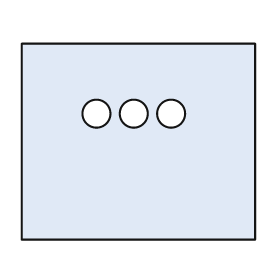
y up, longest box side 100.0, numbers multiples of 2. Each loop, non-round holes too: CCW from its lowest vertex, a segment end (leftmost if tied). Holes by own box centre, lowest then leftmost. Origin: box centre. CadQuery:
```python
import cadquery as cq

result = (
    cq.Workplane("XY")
    .moveTo(-50.0, -42.0)
    .lineTo(50.0, -42.0)
    .lineTo(50.0, 42.0)
    .lineTo(-50.0, 42.0)
    .close()
    .moveTo(-18.0, 12.0)
    .circle(6.0)
    .moveTo(-2.0, 12.0)
    .circle(6.0)
    .moveTo(14.0, 12.0)
    .circle(6.0)
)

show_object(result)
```